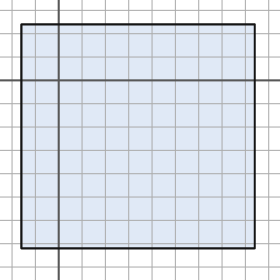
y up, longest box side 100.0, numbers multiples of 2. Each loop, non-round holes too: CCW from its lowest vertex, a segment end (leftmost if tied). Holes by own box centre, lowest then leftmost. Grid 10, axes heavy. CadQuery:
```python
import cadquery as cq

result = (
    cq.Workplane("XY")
    .moveTo(-16.0, -72.0)
    .lineTo(84.0, -72.0)
    .lineTo(84.0, 24.0)
    .lineTo(-16.0, 24.0)
    .close()
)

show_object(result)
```